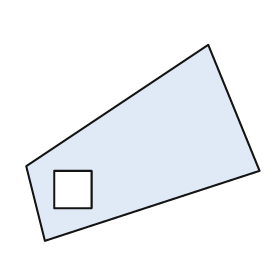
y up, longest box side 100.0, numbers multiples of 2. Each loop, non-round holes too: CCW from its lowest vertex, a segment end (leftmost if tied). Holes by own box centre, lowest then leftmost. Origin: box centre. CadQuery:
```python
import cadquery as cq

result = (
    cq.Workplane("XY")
    .moveTo(-42.0, -42.0)
    .lineTo(50.0, -12.0)
    .lineTo(28.0, 42.0)
    .lineTo(-50.0, -10.0)
    .close()
    .moveTo(-38.0, -28.0)
    .lineTo(-22.0, -28.0)
    .lineTo(-22.0, -12.0)
    .lineTo(-38.0, -12.0)
    .close()
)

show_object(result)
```